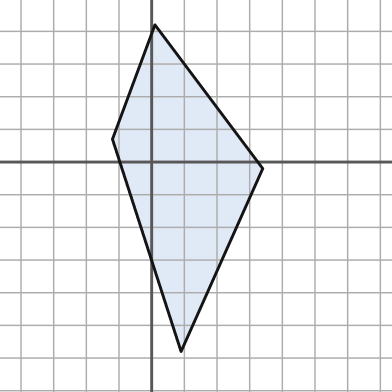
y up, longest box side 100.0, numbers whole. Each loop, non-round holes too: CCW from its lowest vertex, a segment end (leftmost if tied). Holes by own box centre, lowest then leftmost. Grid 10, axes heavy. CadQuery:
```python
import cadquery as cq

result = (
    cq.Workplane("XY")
    .moveTo(9.0, -58.0)
    .lineTo(34.0, -2.0)
    .lineTo(1.0, 42.0)
    .lineTo(-12.0, 7.0)
    .close()
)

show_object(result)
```